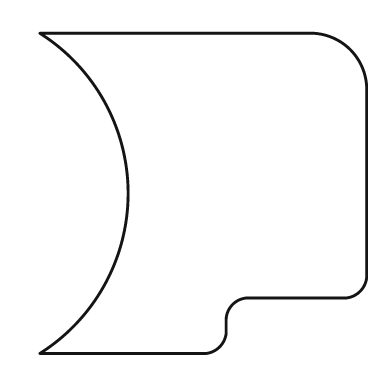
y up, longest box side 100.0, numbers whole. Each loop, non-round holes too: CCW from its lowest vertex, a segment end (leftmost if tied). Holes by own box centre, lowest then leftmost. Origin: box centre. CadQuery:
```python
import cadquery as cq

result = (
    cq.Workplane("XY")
    .moveTo(-50.0, -49.0)
    .lineTo(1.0, -49.0)
    .threePointArc((5.0, -47.0), (7.0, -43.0))
    .lineTo(7.0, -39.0)
    .threePointArc((9.0, -34.0), (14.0, -32.0))
    .lineTo(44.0, -32.0)
    .threePointArc((48.0, -30.0), (50.0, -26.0))
    .lineTo(50.0, 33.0)
    .threePointArc((45.0, 44.0), (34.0, 49.0))
    .lineTo(-50.0, 49.0)
    .threePointArc((-23.0, 0.0), (-50.0, -49.0))
    .close()
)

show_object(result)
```